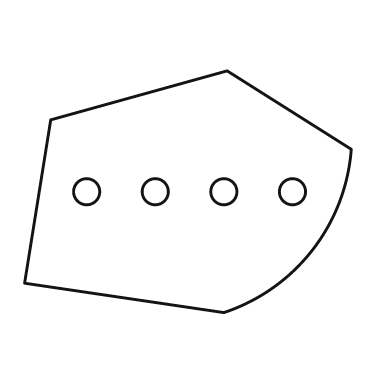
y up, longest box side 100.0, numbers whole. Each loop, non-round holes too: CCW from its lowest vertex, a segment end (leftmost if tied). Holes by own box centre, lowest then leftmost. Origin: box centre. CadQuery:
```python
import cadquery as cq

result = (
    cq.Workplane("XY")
    .moveTo(11.0, -37.0)
    .threePointArc((38.0, -18.0), (50.0, 13.0))
    .lineTo(12.0, 37.0)
    .lineTo(-42.0, 22.0)
    .lineTo(-50.0, -28.0)
    .close()
    .moveTo(-31.0, 0.0)
    .circle(4.0)
    .moveTo(-10.0, 0.0)
    .circle(4.0)
    .moveTo(11.0, 0.0)
    .circle(4.0)
    .moveTo(32.0, 0.0)
    .circle(4.0)
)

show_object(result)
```